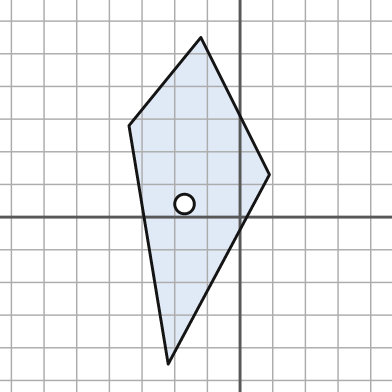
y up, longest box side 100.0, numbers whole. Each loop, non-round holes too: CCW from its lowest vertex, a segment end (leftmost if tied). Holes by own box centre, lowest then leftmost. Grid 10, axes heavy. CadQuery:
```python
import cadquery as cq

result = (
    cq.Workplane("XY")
    .moveTo(-22.0, -45.0)
    .lineTo(9.0, 13.0)
    .lineTo(-12.0, 55.0)
    .lineTo(-34.0, 28.0)
    .close()
    .moveTo(-17.0, 4.0)
    .circle(3.0)
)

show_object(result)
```